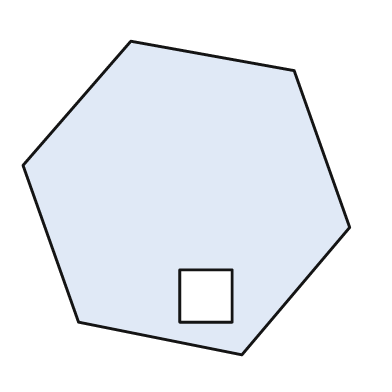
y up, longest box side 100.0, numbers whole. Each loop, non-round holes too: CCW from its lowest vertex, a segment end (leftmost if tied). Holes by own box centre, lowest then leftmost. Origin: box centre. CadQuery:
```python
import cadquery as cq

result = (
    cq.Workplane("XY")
    .moveTo(17.0, -48.0)
    .lineTo(50.0, -9.0)
    .lineTo(33.0, 39.0)
    .lineTo(-17.0, 48.0)
    .lineTo(-50.0, 10.0)
    .lineTo(-33.0, -38.0)
    .close()
    .moveTo(-2.0, -38.0)
    .lineTo(14.0, -38.0)
    .lineTo(14.0, -22.0)
    .lineTo(-2.0, -22.0)
    .close()
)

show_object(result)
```